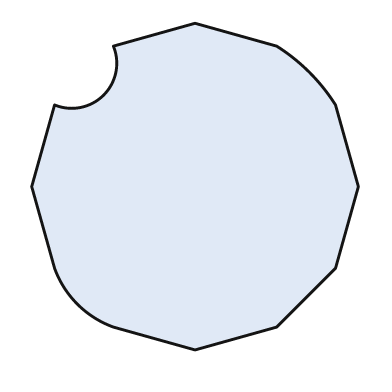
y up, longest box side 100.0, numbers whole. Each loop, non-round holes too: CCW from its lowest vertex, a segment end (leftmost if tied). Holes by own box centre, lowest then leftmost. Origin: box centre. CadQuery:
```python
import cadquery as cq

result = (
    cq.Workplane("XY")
    .moveTo(0.0, -50.0)
    .lineTo(25.0, -43.0)
    .lineTo(43.0, -25.0)
    .lineTo(50.0, 0.0)
    .lineTo(43.0, 25.0)
    .threePointArc((35.0, 35.0), (25.0, 43.0))
    .lineTo(0.0, 50.0)
    .lineTo(-25.0, 43.0)
    .threePointArc((-28.0, 28.0), (-43.0, 25.0))
    .lineTo(-50.0, 0.0)
    .lineTo(-43.0, -25.0)
    .threePointArc((-36.0, -36.0), (-25.0, -43.0))
    .close()
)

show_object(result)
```